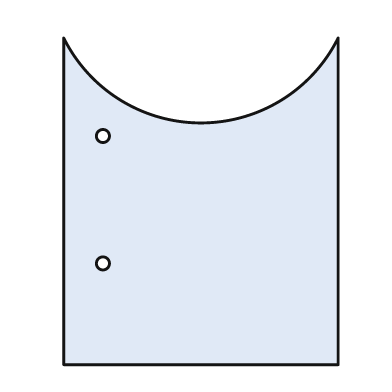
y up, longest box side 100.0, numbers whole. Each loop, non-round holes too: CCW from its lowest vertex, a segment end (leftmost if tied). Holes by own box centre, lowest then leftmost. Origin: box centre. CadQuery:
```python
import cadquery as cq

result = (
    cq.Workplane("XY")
    .moveTo(-42.0, -50.0)
    .lineTo(42.0, -50.0)
    .lineTo(42.0, 50.0)
    .threePointArc((0.0, 24.0), (-42.0, 50.0))
    .close()
    .moveTo(-30.0, -19.0)
    .circle(2.0)
    .moveTo(-30.0, 20.0)
    .circle(2.0)
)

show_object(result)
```